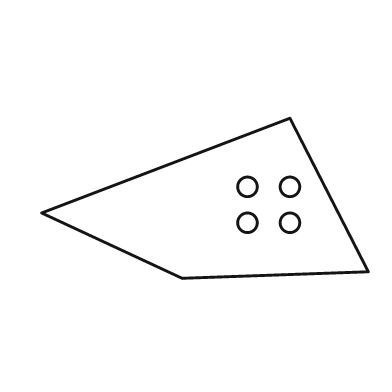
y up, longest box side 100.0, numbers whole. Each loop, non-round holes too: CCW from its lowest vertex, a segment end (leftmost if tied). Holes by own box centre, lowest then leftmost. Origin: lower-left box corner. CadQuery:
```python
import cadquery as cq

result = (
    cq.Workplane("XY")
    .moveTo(43.0, 0.0)
    .lineTo(100.0, 2.0)
    .lineTo(76.0, 49.0)
    .lineTo(0.0, 20.0)
    .close()
    .moveTo(63.0, 17.0)
    .circle(3.0)
    .moveTo(76.0, 17.0)
    .circle(3.0)
    .moveTo(63.0, 28.0)
    .circle(3.0)
    .moveTo(76.0, 28.0)
    .circle(3.0)
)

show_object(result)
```